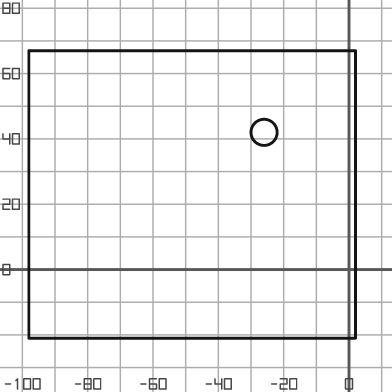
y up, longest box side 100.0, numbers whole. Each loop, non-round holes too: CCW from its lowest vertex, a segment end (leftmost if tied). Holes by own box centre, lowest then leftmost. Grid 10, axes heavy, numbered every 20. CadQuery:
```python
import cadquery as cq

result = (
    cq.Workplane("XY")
    .moveTo(-98.0, -21.0)
    .lineTo(2.0, -21.0)
    .lineTo(2.0, 67.0)
    .lineTo(-98.0, 67.0)
    .close()
    .moveTo(-26.0, 42.0)
    .circle(4.0)
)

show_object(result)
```